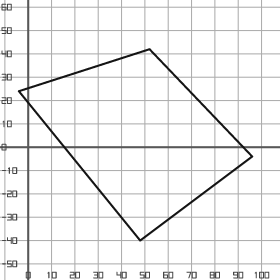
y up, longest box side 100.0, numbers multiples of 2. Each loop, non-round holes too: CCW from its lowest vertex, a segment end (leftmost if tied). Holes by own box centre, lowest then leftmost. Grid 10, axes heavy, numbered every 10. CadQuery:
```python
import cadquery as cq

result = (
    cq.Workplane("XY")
    .moveTo(48.0, -40.0)
    .lineTo(96.0, -4.0)
    .lineTo(52.0, 42.0)
    .lineTo(-4.0, 24.0)
    .close()
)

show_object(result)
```